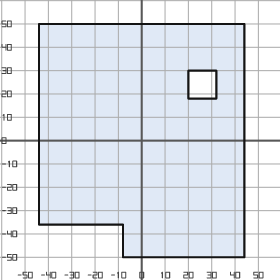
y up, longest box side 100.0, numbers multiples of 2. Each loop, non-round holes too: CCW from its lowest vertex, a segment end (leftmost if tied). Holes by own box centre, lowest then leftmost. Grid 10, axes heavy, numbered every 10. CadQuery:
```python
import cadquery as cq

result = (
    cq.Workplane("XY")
    .moveTo(-8.0, -50.0)
    .lineTo(44.0, -50.0)
    .lineTo(44.0, 50.0)
    .lineTo(-44.0, 50.0)
    .lineTo(-44.0, -36.0)
    .lineTo(-8.0, -36.0)
    .close()
    .moveTo(20.0, 18.0)
    .lineTo(32.0, 18.0)
    .lineTo(32.0, 30.0)
    .lineTo(20.0, 30.0)
    .close()
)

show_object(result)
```